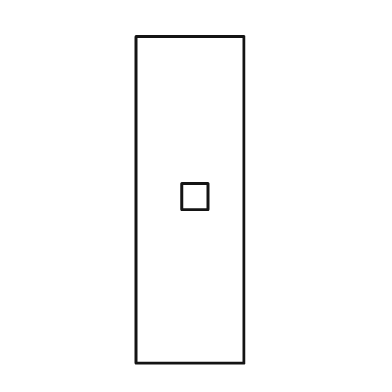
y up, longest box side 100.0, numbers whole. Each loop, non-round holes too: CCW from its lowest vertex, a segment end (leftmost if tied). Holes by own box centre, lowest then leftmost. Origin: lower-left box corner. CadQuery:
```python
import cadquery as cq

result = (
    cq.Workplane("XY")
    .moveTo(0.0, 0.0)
    .lineTo(33.0, 0.0)
    .lineTo(33.0, 100.0)
    .lineTo(0.0, 100.0)
    .close()
    .moveTo(14.0, 47.0)
    .lineTo(22.0, 47.0)
    .lineTo(22.0, 55.0)
    .lineTo(14.0, 55.0)
    .close()
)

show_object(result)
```